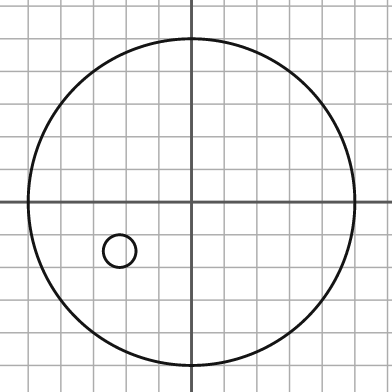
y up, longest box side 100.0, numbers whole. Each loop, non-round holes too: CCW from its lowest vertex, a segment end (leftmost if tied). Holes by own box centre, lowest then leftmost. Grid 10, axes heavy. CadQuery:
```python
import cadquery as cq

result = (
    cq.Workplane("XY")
    .moveTo(0.0, 0.0)
    .circle(50.0)
    .moveTo(-22.0, -15.0)
    .circle(5.0)
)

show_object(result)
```